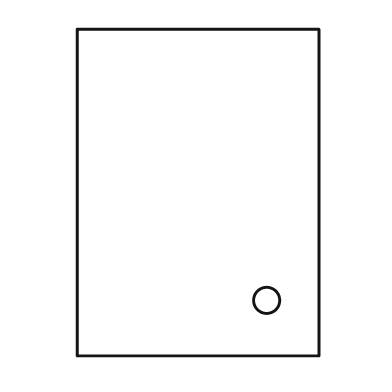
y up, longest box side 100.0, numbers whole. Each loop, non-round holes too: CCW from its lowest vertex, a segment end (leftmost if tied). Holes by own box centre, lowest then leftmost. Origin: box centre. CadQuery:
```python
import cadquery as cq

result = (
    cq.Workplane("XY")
    .moveTo(-37.0, -50.0)
    .lineTo(37.0, -50.0)
    .lineTo(37.0, 50.0)
    .lineTo(-37.0, 50.0)
    .close()
    .moveTo(21.0, -33.0)
    .circle(4.0)
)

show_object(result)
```